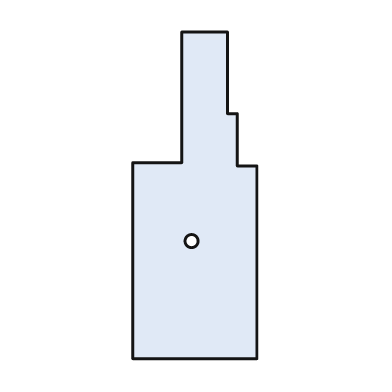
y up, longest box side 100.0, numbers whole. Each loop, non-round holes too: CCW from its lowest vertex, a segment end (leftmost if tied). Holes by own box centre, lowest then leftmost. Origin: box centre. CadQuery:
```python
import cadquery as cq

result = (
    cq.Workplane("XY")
    .moveTo(-19.0, -50.0)
    .lineTo(19.0, -50.0)
    .lineTo(19.0, 9.0)
    .lineTo(13.0, 9.0)
    .lineTo(13.0, 25.0)
    .lineTo(10.0, 25.0)
    .lineTo(10.0, 50.0)
    .lineTo(-4.0, 50.0)
    .lineTo(-4.0, 10.0)
    .lineTo(-19.0, 10.0)
    .close()
    .moveTo(-1.0, -14.0)
    .circle(2.0)
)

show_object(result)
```